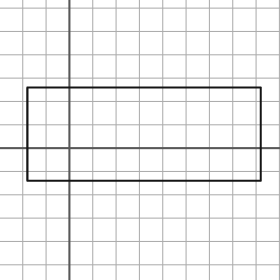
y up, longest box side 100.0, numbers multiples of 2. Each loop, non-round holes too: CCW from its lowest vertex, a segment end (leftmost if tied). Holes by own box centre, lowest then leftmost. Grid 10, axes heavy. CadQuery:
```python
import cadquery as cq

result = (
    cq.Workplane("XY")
    .moveTo(-18.0, -14.0)
    .lineTo(82.0, -14.0)
    .lineTo(82.0, 26.0)
    .lineTo(-18.0, 26.0)
    .close()
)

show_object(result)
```